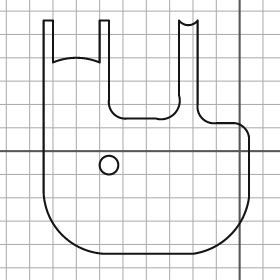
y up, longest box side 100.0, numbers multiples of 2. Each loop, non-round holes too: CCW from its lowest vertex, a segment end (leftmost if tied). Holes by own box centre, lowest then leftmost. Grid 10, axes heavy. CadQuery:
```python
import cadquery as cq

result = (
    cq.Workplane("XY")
    .moveTo(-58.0, -44.0)
    .lineTo(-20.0, -44.0)
    .threePointArc((-4.0, -36.0), (4.0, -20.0))
    .lineTo(4.0, 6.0)
    .threePointArc((2.0, 10.0), (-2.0, 12.0))
    .lineTo(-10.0, 12.0)
    .threePointArc((-16.0, 14.0), (-18.0, 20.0))
    .lineTo(-18.0, 56.0)
    .threePointArc((-22.0, 54.0), (-26.0, 56.0))
    .lineTo(-26.0, 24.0)
    .threePointArc((-28.0, 16.0), (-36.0, 14.0))
    .lineTo(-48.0, 14.0)
    .threePointArc((-54.0, 16.0), (-56.0, 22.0))
    .lineTo(-56.0, 56.0)
    .lineTo(-60.0, 56.0)
    .lineTo(-60.0, 38.0)
    .threePointArc((-70.0, 40.0), (-80.0, 38.0))
    .lineTo(-80.0, 56.0)
    .lineTo(-84.0, 56.0)
    .lineTo(-84.0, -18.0)
    .threePointArc((-76.0, -36.0), (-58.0, -44.0))
    .close()
    .moveTo(-56.0, -6.0)
    .circle(4.0)
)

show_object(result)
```